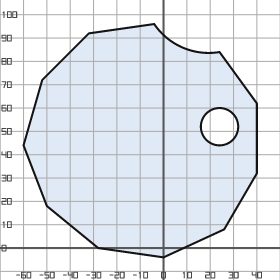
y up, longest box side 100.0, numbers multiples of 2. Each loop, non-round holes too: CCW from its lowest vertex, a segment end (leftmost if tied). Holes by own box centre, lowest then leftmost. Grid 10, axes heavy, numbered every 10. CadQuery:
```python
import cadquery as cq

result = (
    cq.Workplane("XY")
    .moveTo(0.0, -4.0)
    .lineTo(26.0, 8.0)
    .lineTo(40.0, 32.0)
    .lineTo(40.0, 62.0)
    .lineTo(24.0, 84.0)
    .threePointArc((8.0, 86.0), (-4.0, 96.0))
    .lineTo(-32.0, 92.0)
    .lineTo(-52.0, 72.0)
    .lineTo(-60.0, 44.0)
    .lineTo(-50.0, 18.0)
    .lineTo(-28.0, 0.0)
    .close()
    .moveTo(24.0, 52.0)
    .circle(8.0)
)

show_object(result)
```